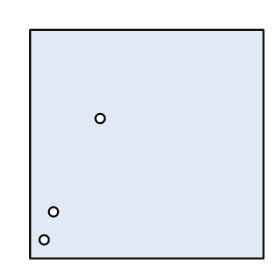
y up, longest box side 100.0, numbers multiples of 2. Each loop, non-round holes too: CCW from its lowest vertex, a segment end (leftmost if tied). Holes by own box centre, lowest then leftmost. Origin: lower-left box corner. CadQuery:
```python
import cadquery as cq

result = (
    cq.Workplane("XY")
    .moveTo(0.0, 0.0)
    .lineTo(100.0, 0.0)
    .lineTo(100.0, 98.0)
    .lineTo(0.0, 98.0)
    .close()
    .moveTo(6.0, 8.0)
    .circle(2.0)
    .moveTo(10.0, 20.0)
    .circle(2.0)
    .moveTo(30.0, 60.0)
    .circle(2.0)
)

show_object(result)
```